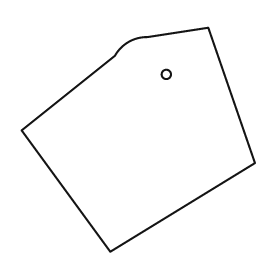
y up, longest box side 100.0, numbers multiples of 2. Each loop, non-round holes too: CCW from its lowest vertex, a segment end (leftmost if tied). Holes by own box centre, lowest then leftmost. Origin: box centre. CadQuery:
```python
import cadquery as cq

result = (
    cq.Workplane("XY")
    .moveTo(-12.0, -48.0)
    .lineTo(50.0, -10.0)
    .lineTo(30.0, 48.0)
    .lineTo(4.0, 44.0)
    .threePointArc((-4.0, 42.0), (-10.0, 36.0))
    .lineTo(-50.0, 4.0)
    .close()
    .moveTo(12.0, 28.0)
    .circle(2.0)
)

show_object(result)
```